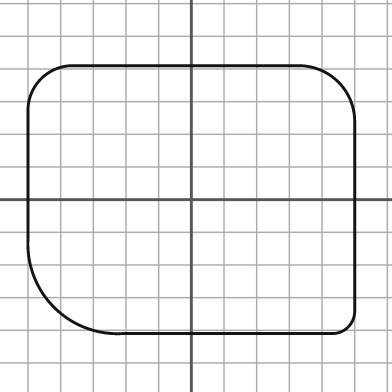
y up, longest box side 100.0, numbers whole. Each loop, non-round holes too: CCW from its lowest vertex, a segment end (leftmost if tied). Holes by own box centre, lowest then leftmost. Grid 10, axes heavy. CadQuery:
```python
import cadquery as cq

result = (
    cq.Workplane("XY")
    .moveTo(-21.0, -41.0)
    .lineTo(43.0, -41.0)
    .threePointArc((48.0, -39.0), (50.0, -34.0))
    .lineTo(50.0, 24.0)
    .threePointArc((45.0, 36.0), (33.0, 41.0))
    .lineTo(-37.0, 41.0)
    .threePointArc((-46.0, 37.0), (-50.0, 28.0))
    .lineTo(-50.0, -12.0)
    .threePointArc((-42.0, -33.0), (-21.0, -41.0))
    .close()
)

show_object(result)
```